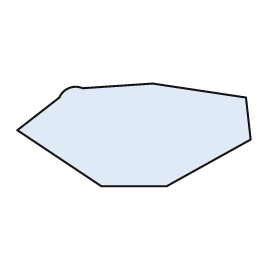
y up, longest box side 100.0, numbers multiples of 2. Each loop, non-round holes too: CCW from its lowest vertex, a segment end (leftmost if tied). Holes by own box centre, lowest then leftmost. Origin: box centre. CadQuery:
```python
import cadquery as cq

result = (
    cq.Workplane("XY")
    .moveTo(-14.0, -22.0)
    .lineTo(14.0, -22.0)
    .lineTo(50.0, -2.0)
    .lineTo(48.0, 16.0)
    .lineTo(8.0, 22.0)
    .lineTo(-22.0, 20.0)
    .threePointArc((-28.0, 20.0), (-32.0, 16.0))
    .lineTo(-50.0, 2.0)
    .close()
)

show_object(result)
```